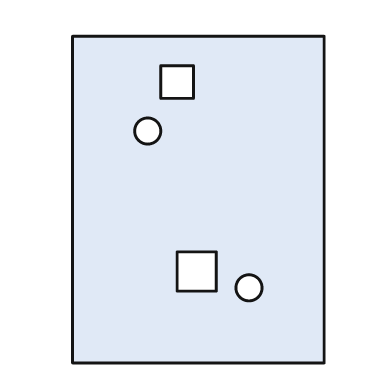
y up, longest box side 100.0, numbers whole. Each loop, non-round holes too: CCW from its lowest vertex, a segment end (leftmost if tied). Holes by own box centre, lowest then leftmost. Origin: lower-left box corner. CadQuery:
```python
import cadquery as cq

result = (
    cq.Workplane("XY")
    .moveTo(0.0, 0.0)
    .lineTo(77.0, 0.0)
    .lineTo(77.0, 100.0)
    .lineTo(0.0, 100.0)
    .close()
    .moveTo(54.0, 23.0)
    .circle(4.0)
    .moveTo(32.0, 22.0)
    .lineTo(44.0, 22.0)
    .lineTo(44.0, 34.0)
    .lineTo(32.0, 34.0)
    .close()
    .moveTo(23.0, 71.0)
    .circle(4.0)
    .moveTo(27.0, 81.0)
    .lineTo(37.0, 81.0)
    .lineTo(37.0, 91.0)
    .lineTo(27.0, 91.0)
    .close()
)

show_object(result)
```